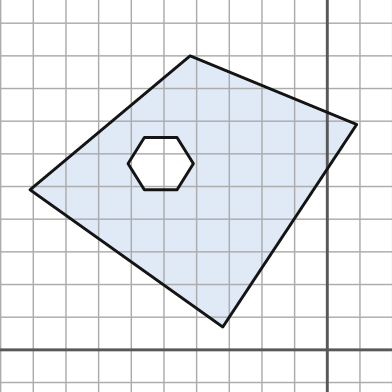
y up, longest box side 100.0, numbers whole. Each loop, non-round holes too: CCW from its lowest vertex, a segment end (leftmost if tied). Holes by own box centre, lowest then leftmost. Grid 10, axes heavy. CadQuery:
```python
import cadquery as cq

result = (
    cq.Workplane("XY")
    .moveTo(-32.0, 7.0)
    .lineTo(9.0, 69.0)
    .lineTo(-42.0, 90.0)
    .lineTo(-91.0, 49.0)
    .close()
    .moveTo(-56.0, 49.0)
    .lineTo(-46.0, 49.0)
    .lineTo(-41.0, 57.0)
    .lineTo(-46.0, 65.0)
    .lineTo(-56.0, 65.0)
    .lineTo(-61.0, 57.0)
    .close()
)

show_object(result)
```